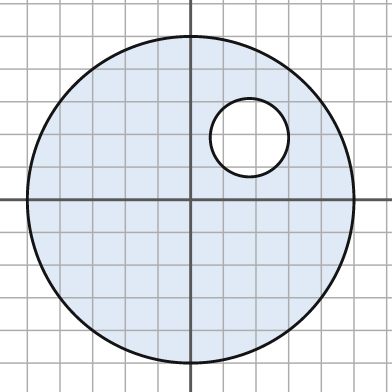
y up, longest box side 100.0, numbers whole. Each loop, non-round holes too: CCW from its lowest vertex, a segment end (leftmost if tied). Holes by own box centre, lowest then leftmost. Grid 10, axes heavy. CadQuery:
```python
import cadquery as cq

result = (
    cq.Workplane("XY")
    .moveTo(0.0, 0.0)
    .circle(50.0)
    .moveTo(18.0, 19.0)
    .circle(12.0)
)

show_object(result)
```